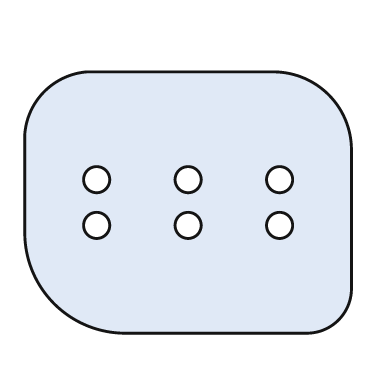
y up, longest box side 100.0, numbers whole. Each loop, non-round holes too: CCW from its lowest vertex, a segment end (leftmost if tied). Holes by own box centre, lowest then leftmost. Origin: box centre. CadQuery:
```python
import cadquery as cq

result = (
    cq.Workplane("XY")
    .moveTo(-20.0, -40.0)
    .lineTo(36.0, -40.0)
    .threePointArc((46.0, -36.0), (50.0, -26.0))
    .lineTo(50.0, 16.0)
    .threePointArc((43.0, 33.0), (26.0, 40.0))
    .lineTo(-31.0, 40.0)
    .threePointArc((-44.0, 34.0), (-50.0, 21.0))
    .lineTo(-50.0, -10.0)
    .threePointArc((-41.0, -31.0), (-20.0, -40.0))
    .close()
    .moveTo(-28.0, -7.0)
    .circle(4.0)
    .moveTo(0.0, -7.0)
    .circle(4.0)
    .moveTo(28.0, -7.0)
    .circle(4.0)
    .moveTo(-28.0, 7.0)
    .circle(4.0)
    .moveTo(0.0, 7.0)
    .circle(4.0)
    .moveTo(28.0, 7.0)
    .circle(4.0)
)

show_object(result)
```